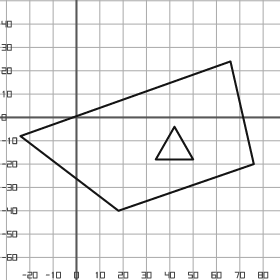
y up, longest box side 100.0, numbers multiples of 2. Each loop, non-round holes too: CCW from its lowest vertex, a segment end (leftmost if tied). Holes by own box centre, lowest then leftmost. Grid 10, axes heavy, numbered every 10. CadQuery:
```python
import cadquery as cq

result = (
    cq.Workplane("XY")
    .moveTo(18.0, -40.0)
    .lineTo(76.0, -20.0)
    .lineTo(66.0, 24.0)
    .lineTo(-24.0, -8.0)
    .close()
    .moveTo(34.0, -18.0)
    .lineTo(50.0, -18.0)
    .lineTo(42.0, -4.0)
    .close()
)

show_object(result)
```